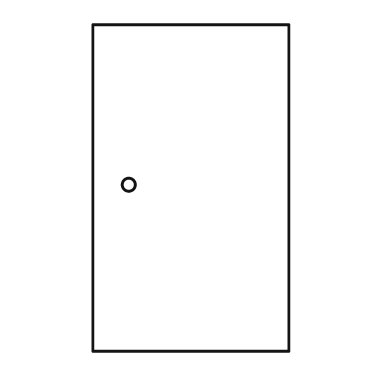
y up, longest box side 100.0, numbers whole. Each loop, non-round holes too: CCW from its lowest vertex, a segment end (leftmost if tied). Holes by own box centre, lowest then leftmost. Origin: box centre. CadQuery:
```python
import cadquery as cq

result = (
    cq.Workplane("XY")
    .moveTo(-30.0, -50.0)
    .lineTo(30.0, -50.0)
    .lineTo(30.0, 50.0)
    .lineTo(-30.0, 50.0)
    .close()
    .moveTo(-19.0, 1.0)
    .circle(2.0)
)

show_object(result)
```